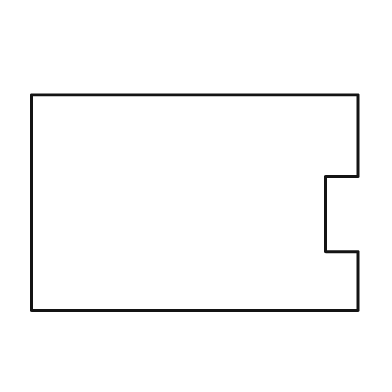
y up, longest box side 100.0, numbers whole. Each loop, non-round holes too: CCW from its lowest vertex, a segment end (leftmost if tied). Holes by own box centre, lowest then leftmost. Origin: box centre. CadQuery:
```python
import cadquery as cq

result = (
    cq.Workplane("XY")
    .moveTo(-50.0, -33.0)
    .lineTo(50.0, -33.0)
    .lineTo(50.0, -15.0)
    .lineTo(40.0, -15.0)
    .lineTo(40.0, 8.0)
    .lineTo(50.0, 8.0)
    .lineTo(50.0, 33.0)
    .lineTo(-50.0, 33.0)
    .close()
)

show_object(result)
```